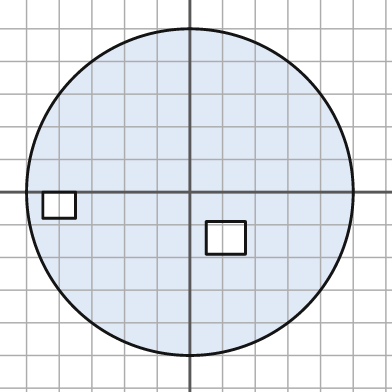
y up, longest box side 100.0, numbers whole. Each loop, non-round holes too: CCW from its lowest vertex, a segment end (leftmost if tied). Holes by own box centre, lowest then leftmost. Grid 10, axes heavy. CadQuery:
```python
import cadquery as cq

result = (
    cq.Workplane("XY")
    .moveTo(0.0, 0.0)
    .circle(50.0)
    .moveTo(5.0, -19.0)
    .lineTo(17.0, -19.0)
    .lineTo(17.0, -9.0)
    .lineTo(5.0, -9.0)
    .close()
    .moveTo(-45.0, -8.0)
    .lineTo(-35.0, -8.0)
    .lineTo(-35.0, 0.0)
    .lineTo(-45.0, 0.0)
    .close()
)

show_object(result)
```